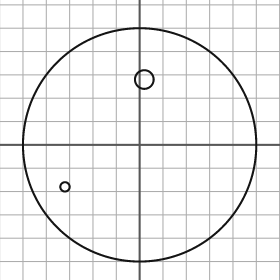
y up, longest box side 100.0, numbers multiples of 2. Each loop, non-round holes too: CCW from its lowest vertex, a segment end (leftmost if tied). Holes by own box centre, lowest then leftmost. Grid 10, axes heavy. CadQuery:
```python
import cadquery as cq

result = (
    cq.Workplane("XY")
    .moveTo(0.0, 0.0)
    .circle(50.0)
    .moveTo(-32.0, -18.0)
    .circle(2.0)
    .moveTo(2.0, 28.0)
    .circle(4.0)
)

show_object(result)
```